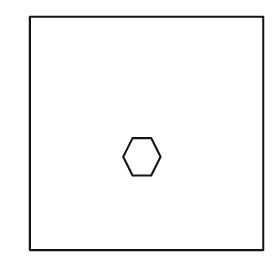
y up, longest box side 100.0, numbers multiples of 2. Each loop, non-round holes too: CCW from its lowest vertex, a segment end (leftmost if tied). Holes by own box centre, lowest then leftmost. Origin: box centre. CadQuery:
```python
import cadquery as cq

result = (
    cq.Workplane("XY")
    .moveTo(-50.0, -50.0)
    .lineTo(50.0, -50.0)
    .lineTo(50.0, 50.0)
    .lineTo(-50.0, 50.0)
    .close()
    .moveTo(-6.0, -18.0)
    .lineTo(2.0, -18.0)
    .lineTo(6.0, -10.0)
    .lineTo(2.0, -2.0)
    .lineTo(-6.0, -2.0)
    .lineTo(-10.0, -10.0)
    .close()
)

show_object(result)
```